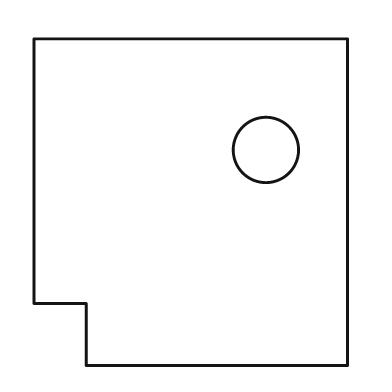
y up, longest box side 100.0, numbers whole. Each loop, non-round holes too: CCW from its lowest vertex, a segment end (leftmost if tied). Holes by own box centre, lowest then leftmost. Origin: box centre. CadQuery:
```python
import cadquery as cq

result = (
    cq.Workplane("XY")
    .moveTo(-32.0, -50.0)
    .lineTo(48.0, -50.0)
    .lineTo(48.0, 50.0)
    .lineTo(-48.0, 50.0)
    .lineTo(-48.0, -31.0)
    .lineTo(-32.0, -31.0)
    .close()
    .moveTo(23.0, 16.0)
    .circle(10.0)
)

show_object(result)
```